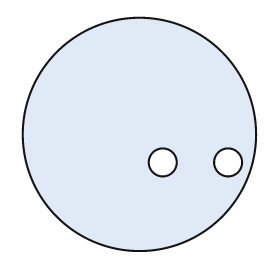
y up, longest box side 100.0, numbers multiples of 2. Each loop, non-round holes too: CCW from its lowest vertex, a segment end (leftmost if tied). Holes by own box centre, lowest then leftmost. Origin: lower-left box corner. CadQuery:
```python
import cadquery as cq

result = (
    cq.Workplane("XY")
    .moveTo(50.0, 50.0)
    .circle(50.0)
    .moveTo(60.0, 38.0)
    .circle(6.0)
    .moveTo(88.0, 38.0)
    .circle(6.0)
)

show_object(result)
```